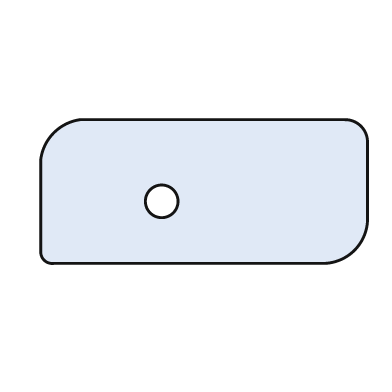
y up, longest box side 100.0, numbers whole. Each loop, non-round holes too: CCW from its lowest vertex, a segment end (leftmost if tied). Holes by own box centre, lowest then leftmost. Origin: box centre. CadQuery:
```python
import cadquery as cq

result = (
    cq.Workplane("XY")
    .moveTo(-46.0, -22.0)
    .lineTo(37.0, -22.0)
    .threePointArc((46.0, -18.0), (50.0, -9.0))
    .lineTo(50.0, 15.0)
    .threePointArc((48.0, 20.0), (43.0, 22.0))
    .lineTo(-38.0, 22.0)
    .threePointArc((-46.0, 18.0), (-50.0, 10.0))
    .lineTo(-50.0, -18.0)
    .threePointArc((-49.0, -21.0), (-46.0, -22.0))
    .close()
    .moveTo(-13.0, -3.0)
    .circle(5.0)
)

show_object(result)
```